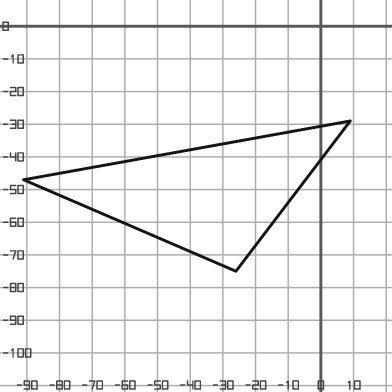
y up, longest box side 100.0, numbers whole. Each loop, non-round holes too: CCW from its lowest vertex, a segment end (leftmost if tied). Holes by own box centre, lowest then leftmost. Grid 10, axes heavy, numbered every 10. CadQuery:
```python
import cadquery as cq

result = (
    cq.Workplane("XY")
    .moveTo(-26.0, -75.0)
    .lineTo(9.0, -29.0)
    .lineTo(-91.0, -47.0)
    .close()
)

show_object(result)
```